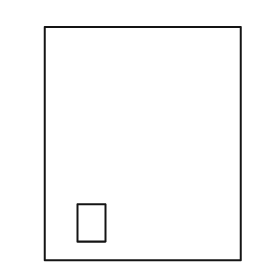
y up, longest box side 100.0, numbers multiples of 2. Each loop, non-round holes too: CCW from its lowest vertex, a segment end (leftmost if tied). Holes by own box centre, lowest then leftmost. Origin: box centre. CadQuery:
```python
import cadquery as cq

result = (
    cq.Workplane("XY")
    .moveTo(-42.0, -50.0)
    .lineTo(42.0, -50.0)
    .lineTo(42.0, 50.0)
    .lineTo(-42.0, 50.0)
    .close()
    .moveTo(-28.0, -42.0)
    .lineTo(-16.0, -42.0)
    .lineTo(-16.0, -26.0)
    .lineTo(-28.0, -26.0)
    .close()
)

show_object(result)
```